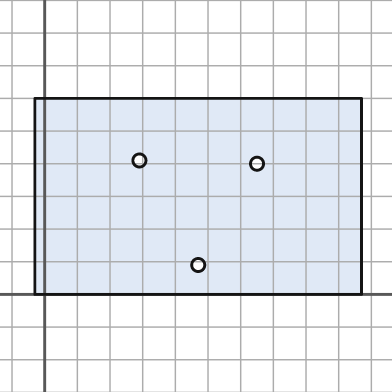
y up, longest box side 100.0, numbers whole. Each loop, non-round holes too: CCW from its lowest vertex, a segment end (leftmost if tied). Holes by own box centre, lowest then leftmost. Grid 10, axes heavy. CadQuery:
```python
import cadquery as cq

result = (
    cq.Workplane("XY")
    .moveTo(-3.0, 0.0)
    .lineTo(97.0, 0.0)
    .lineTo(97.0, 60.0)
    .lineTo(-3.0, 60.0)
    .close()
    .moveTo(47.0, 9.0)
    .circle(2.0)
    .moveTo(65.0, 40.0)
    .circle(2.0)
    .moveTo(29.0, 41.0)
    .circle(2.0)
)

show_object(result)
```